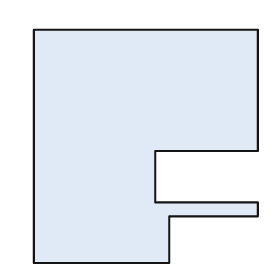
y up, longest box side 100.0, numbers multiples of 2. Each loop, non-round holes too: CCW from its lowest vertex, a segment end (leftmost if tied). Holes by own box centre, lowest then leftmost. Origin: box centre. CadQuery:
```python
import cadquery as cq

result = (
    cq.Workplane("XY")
    .moveTo(-48.0, -50.0)
    .lineTo(10.0, -50.0)
    .lineTo(10.0, -30.0)
    .lineTo(48.0, -30.0)
    .lineTo(48.0, -24.0)
    .lineTo(4.0, -24.0)
    .lineTo(4.0, -2.0)
    .lineTo(48.0, -2.0)
    .lineTo(48.0, 50.0)
    .lineTo(-48.0, 50.0)
    .close()
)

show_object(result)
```